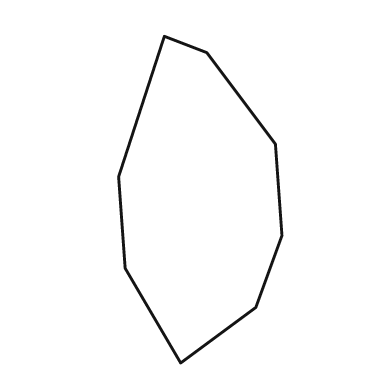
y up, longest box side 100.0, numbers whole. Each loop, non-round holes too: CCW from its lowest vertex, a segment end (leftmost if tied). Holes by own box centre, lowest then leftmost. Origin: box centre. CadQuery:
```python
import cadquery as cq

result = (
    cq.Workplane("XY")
    .moveTo(-6.0, -50.0)
    .lineTo(17.0, -33.0)
    .lineTo(25.0, -11.0)
    .lineTo(23.0, 17.0)
    .lineTo(2.0, 45.0)
    .lineTo(-11.0, 50.0)
    .lineTo(-25.0, 7.0)
    .lineTo(-23.0, -21.0)
    .close()
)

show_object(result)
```